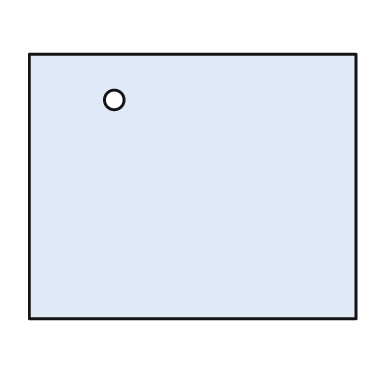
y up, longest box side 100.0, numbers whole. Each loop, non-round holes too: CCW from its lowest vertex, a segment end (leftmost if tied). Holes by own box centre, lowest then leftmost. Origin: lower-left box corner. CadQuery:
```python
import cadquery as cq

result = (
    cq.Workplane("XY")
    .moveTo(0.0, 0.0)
    .lineTo(100.0, 0.0)
    .lineTo(100.0, 81.0)
    .lineTo(0.0, 81.0)
    .close()
    .moveTo(26.0, 67.0)
    .circle(3.0)
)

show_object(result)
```